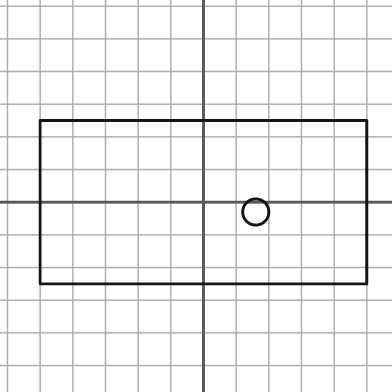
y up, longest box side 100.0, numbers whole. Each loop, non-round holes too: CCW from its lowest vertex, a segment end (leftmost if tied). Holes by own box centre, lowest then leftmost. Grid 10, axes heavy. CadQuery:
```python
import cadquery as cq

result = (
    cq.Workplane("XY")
    .moveTo(-50.0, -25.0)
    .lineTo(50.0, -25.0)
    .lineTo(50.0, 25.0)
    .lineTo(-50.0, 25.0)
    .close()
    .moveTo(16.0, -3.0)
    .circle(4.0)
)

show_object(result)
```